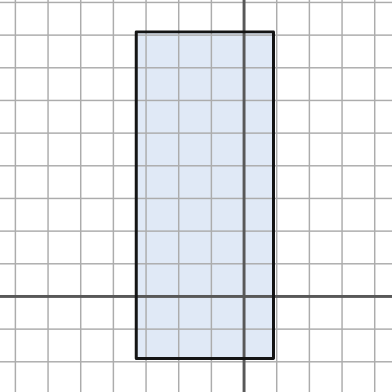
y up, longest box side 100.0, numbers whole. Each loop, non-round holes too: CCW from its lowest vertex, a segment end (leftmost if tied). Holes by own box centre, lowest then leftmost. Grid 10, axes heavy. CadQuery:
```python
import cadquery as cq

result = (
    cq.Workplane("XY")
    .moveTo(-33.0, -19.0)
    .lineTo(9.0, -19.0)
    .lineTo(9.0, 81.0)
    .lineTo(-33.0, 81.0)
    .close()
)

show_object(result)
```